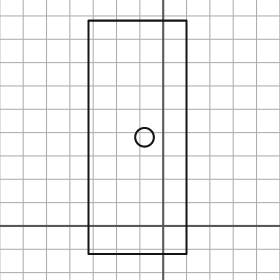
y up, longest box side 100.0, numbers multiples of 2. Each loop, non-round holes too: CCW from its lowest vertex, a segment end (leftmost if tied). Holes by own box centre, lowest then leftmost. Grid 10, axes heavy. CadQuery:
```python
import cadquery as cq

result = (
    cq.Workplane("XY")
    .moveTo(-32.0, -12.0)
    .lineTo(10.0, -12.0)
    .lineTo(10.0, 88.0)
    .lineTo(-32.0, 88.0)
    .close()
    .moveTo(-8.0, 38.0)
    .circle(4.0)
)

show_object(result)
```